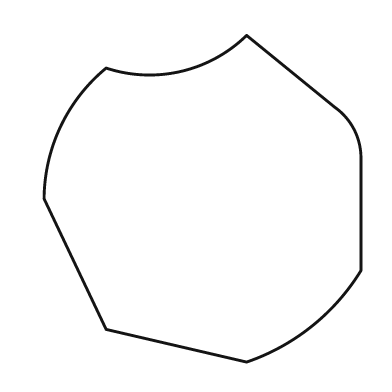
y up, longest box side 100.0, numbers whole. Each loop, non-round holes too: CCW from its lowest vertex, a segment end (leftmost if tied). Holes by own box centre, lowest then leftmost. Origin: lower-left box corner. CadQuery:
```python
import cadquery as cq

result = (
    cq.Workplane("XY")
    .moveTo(62.0, 0.0)
    .threePointArc((82.0, 11.0), (97.0, 28.0))
    .lineTo(97.0, 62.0)
    .threePointArc((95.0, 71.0), (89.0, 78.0))
    .lineTo(62.0, 100.0)
    .threePointArc((42.0, 89.0), (19.0, 90.0))
    .threePointArc((5.0, 72.0), (0.0, 50.0))
    .lineTo(19.0, 10.0)
    .close()
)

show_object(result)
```